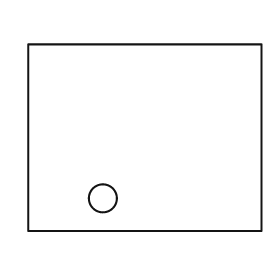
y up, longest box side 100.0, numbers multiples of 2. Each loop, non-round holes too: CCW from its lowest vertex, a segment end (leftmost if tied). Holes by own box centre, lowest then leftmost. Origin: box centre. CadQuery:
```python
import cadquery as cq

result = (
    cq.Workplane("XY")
    .moveTo(-50.0, -40.0)
    .lineTo(50.0, -40.0)
    .lineTo(50.0, 40.0)
    .lineTo(-50.0, 40.0)
    .close()
    .moveTo(-18.0, -26.0)
    .circle(6.0)
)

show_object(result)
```